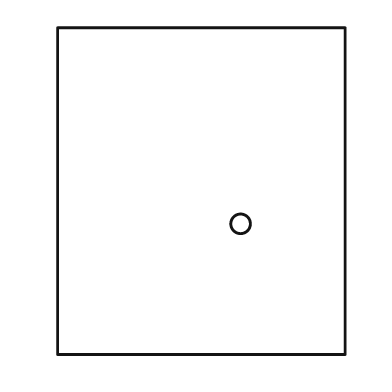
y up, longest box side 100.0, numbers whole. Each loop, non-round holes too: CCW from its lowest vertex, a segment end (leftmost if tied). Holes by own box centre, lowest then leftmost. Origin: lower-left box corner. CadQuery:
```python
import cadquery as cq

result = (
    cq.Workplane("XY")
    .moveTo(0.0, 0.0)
    .lineTo(88.0, 0.0)
    .lineTo(88.0, 100.0)
    .lineTo(0.0, 100.0)
    .close()
    .moveTo(56.0, 40.0)
    .circle(3.0)
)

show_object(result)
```